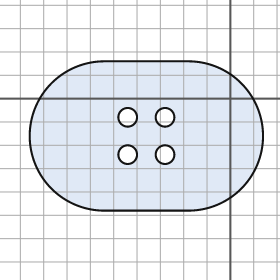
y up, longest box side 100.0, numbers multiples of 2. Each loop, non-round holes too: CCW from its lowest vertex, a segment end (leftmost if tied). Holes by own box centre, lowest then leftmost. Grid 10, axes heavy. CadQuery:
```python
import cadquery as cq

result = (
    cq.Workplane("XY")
    .moveTo(-54.0, -48.0)
    .lineTo(-18.0, -48.0)
    .threePointArc((14.0, -16.0), (-18.0, 16.0))
    .lineTo(-54.0, 16.0)
    .threePointArc((-86.0, -16.0), (-54.0, -48.0))
    .close()
    .moveTo(-44.0, -24.0)
    .circle(4.0)
    .moveTo(-28.0, -24.0)
    .circle(4.0)
    .moveTo(-44.0, -8.0)
    .circle(4.0)
    .moveTo(-28.0, -8.0)
    .circle(4.0)
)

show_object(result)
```